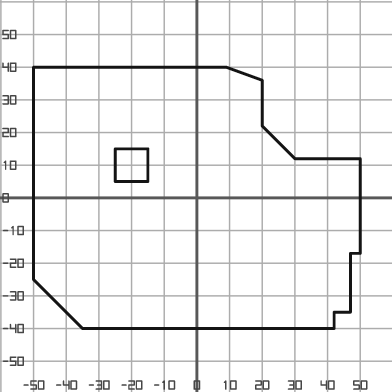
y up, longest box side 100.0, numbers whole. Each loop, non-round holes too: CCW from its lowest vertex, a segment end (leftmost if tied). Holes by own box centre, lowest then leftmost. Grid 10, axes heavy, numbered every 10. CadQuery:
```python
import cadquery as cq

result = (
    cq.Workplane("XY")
    .moveTo(-35.0, -40.0)
    .lineTo(42.0, -40.0)
    .lineTo(42.0, -35.0)
    .lineTo(47.0, -35.0)
    .lineTo(47.0, -17.0)
    .lineTo(50.0, -17.0)
    .lineTo(50.0, 12.0)
    .lineTo(30.0, 12.0)
    .lineTo(20.0, 22.0)
    .lineTo(20.0, 36.0)
    .lineTo(9.0, 40.0)
    .lineTo(-50.0, 40.0)
    .lineTo(-50.0, -25.0)
    .close()
    .moveTo(-25.0, 5.0)
    .lineTo(-15.0, 5.0)
    .lineTo(-15.0, 15.0)
    .lineTo(-25.0, 15.0)
    .close()
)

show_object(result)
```